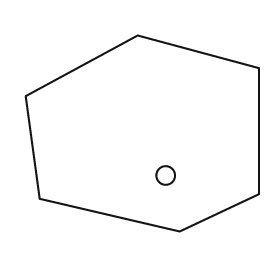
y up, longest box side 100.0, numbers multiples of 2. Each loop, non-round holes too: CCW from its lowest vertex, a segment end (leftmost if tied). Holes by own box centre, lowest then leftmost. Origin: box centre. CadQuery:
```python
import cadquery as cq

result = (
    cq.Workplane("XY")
    .moveTo(16.0, -42.0)
    .lineTo(50.0, -26.0)
    .lineTo(50.0, 28.0)
    .lineTo(-2.0, 42.0)
    .lineTo(-50.0, 16.0)
    .lineTo(-44.0, -28.0)
    .close()
    .moveTo(10.0, -18.0)
    .circle(4.0)
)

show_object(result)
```